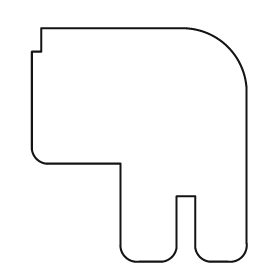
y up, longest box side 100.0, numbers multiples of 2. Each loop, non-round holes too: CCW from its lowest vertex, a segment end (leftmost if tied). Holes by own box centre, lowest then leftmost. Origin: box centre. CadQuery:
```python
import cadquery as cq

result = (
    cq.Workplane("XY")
    .moveTo(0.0, -50.0)
    .lineTo(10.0, -50.0)
    .threePointArc((14.0, -48.0), (16.0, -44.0))
    .lineTo(16.0, -22.0)
    .lineTo(24.0, -22.0)
    .lineTo(24.0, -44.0)
    .threePointArc((26.0, -48.0), (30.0, -50.0))
    .lineTo(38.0, -50.0)
    .threePointArc((44.0, -48.0), (46.0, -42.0))
    .lineTo(46.0, 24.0)
    .threePointArc((38.0, 42.0), (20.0, 50.0))
    .lineTo(-42.0, 50.0)
    .lineTo(-42.0, 40.0)
    .lineTo(-46.0, 40.0)
    .lineTo(-46.0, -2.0)
    .threePointArc((-44.0, -6.0), (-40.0, -8.0))
    .lineTo(-8.0, -8.0)
    .lineTo(-8.0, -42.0)
    .threePointArc((-6.0, -48.0), (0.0, -50.0))
    .close()
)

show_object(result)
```